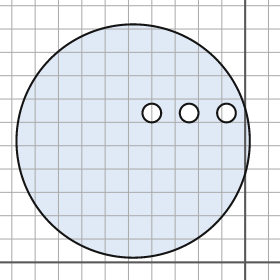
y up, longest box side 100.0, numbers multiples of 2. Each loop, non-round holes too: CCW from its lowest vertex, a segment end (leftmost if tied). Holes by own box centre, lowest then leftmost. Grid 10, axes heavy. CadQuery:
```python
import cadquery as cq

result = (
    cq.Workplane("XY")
    .moveTo(-48.0, 52.0)
    .circle(50.0)
    .moveTo(-40.0, 64.0)
    .circle(4.0)
    .moveTo(-24.0, 64.0)
    .circle(4.0)
    .moveTo(-8.0, 64.0)
    .circle(4.0)
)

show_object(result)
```